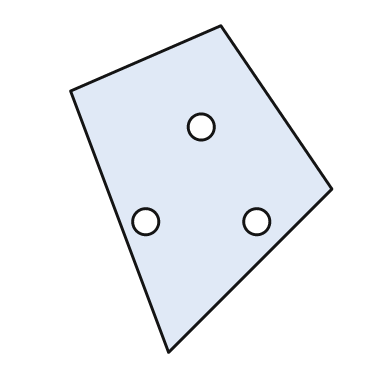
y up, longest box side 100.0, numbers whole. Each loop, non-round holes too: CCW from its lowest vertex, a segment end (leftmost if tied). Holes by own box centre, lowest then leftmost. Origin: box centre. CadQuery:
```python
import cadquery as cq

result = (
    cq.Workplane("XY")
    .moveTo(-10.0, -50.0)
    .lineTo(40.0, 0.0)
    .lineTo(6.0, 50.0)
    .lineTo(-40.0, 30.0)
    .close()
    .moveTo(-17.0, -10.0)
    .circle(4.0)
    .moveTo(17.0, -10.0)
    .circle(4.0)
    .moveTo(0.0, 19.0)
    .circle(4.0)
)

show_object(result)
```